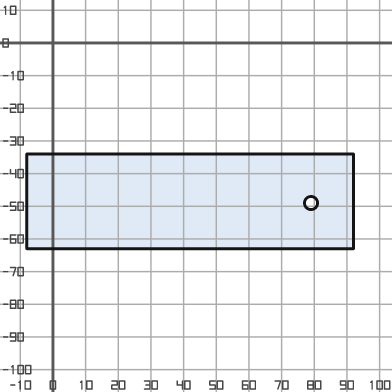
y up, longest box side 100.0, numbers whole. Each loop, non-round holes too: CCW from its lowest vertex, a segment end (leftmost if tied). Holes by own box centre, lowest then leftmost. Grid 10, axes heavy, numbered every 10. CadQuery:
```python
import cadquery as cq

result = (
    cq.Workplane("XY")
    .moveTo(-8.0, -63.0)
    .lineTo(92.0, -63.0)
    .lineTo(92.0, -34.0)
    .lineTo(-8.0, -34.0)
    .close()
    .moveTo(79.0, -49.0)
    .circle(2.0)
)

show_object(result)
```